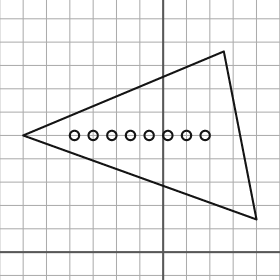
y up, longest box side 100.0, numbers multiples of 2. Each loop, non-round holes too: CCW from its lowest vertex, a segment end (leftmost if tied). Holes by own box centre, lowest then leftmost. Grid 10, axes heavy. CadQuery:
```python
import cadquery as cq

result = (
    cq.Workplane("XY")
    .moveTo(40.0, 14.0)
    .lineTo(26.0, 86.0)
    .lineTo(-60.0, 50.0)
    .close()
    .moveTo(-38.0, 50.0)
    .circle(2.0)
    .moveTo(-30.0, 50.0)
    .circle(2.0)
    .moveTo(-22.0, 50.0)
    .circle(2.0)
    .moveTo(-14.0, 50.0)
    .circle(2.0)
    .moveTo(-6.0, 50.0)
    .circle(2.0)
    .moveTo(2.0, 50.0)
    .circle(2.0)
    .moveTo(10.0, 50.0)
    .circle(2.0)
    .moveTo(18.0, 50.0)
    .circle(2.0)
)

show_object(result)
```